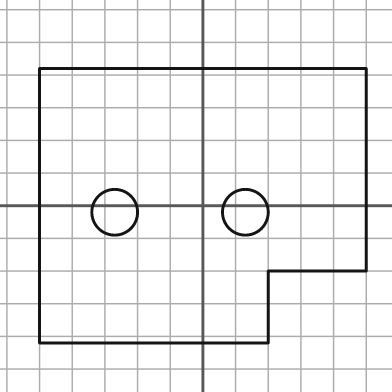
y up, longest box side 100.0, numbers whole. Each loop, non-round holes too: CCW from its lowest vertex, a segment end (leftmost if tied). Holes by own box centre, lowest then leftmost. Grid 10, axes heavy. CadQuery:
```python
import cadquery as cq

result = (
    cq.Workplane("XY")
    .moveTo(-50.0, -42.0)
    .lineTo(20.0, -42.0)
    .lineTo(20.0, -20.0)
    .lineTo(50.0, -20.0)
    .lineTo(50.0, 42.0)
    .lineTo(-50.0, 42.0)
    .close()
    .moveTo(-27.0, -2.0)
    .circle(7.0)
    .moveTo(13.0, -2.0)
    .circle(7.0)
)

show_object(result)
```